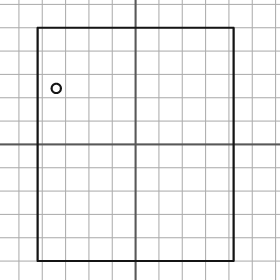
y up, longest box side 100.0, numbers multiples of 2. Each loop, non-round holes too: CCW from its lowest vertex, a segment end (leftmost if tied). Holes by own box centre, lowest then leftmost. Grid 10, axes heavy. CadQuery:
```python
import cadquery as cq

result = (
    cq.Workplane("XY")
    .moveTo(-42.0, -50.0)
    .lineTo(42.0, -50.0)
    .lineTo(42.0, 50.0)
    .lineTo(-42.0, 50.0)
    .close()
    .moveTo(-34.0, 24.0)
    .circle(2.0)
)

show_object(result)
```